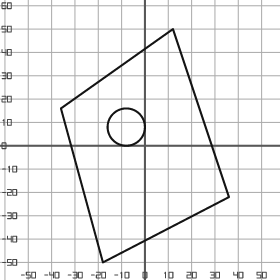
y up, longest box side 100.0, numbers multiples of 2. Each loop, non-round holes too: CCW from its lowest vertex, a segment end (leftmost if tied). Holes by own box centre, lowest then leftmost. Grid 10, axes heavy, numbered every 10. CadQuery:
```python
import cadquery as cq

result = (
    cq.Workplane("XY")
    .moveTo(-18.0, -50.0)
    .lineTo(36.0, -22.0)
    .lineTo(12.0, 50.0)
    .lineTo(-36.0, 16.0)
    .close()
    .moveTo(-8.0, 8.0)
    .circle(8.0)
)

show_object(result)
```